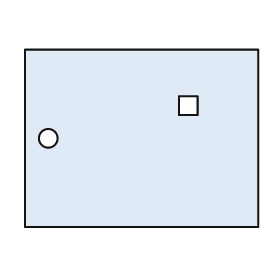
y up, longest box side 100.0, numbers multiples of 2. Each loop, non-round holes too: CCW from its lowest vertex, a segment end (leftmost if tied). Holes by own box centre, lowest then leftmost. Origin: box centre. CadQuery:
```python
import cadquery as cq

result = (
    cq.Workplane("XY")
    .moveTo(-50.0, -38.0)
    .lineTo(50.0, -38.0)
    .lineTo(50.0, 38.0)
    .lineTo(-50.0, 38.0)
    .close()
    .moveTo(-40.0, 0.0)
    .circle(4.0)
    .moveTo(16.0, 10.0)
    .lineTo(24.0, 10.0)
    .lineTo(24.0, 18.0)
    .lineTo(16.0, 18.0)
    .close()
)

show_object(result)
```